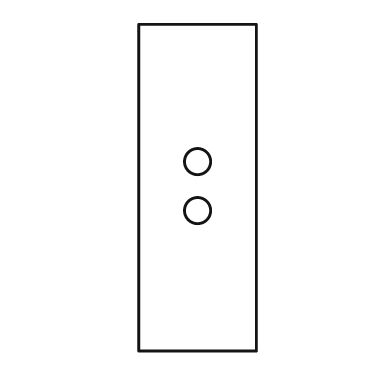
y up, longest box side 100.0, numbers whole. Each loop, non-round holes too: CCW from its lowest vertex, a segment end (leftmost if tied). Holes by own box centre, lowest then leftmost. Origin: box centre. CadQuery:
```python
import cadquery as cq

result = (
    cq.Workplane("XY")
    .moveTo(-18.0, -50.0)
    .lineTo(18.0, -50.0)
    .lineTo(18.0, 50.0)
    .lineTo(-18.0, 50.0)
    .close()
    .moveTo(0.0, -7.0)
    .circle(4.0)
    .moveTo(0.0, 8.0)
    .circle(4.0)
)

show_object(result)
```